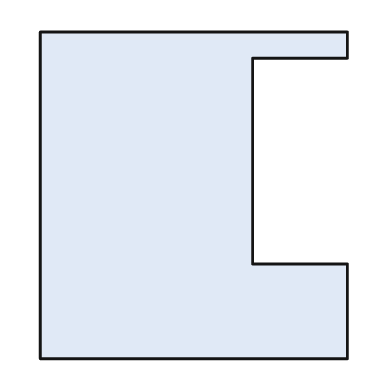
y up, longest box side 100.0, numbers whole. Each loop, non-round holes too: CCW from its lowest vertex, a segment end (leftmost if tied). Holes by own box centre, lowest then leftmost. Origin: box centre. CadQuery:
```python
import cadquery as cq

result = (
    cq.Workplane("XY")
    .moveTo(-47.0, -50.0)
    .lineTo(47.0, -50.0)
    .lineTo(47.0, -21.0)
    .lineTo(18.0, -21.0)
    .lineTo(18.0, 42.0)
    .lineTo(47.0, 42.0)
    .lineTo(47.0, 50.0)
    .lineTo(-47.0, 50.0)
    .close()
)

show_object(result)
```